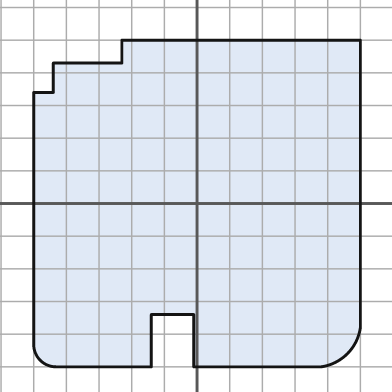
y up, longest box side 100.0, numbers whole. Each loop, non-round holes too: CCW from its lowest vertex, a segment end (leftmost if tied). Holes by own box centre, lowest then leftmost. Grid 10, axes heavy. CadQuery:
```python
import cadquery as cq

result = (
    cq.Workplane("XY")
    .moveTo(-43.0, -50.0)
    .lineTo(-14.0, -50.0)
    .lineTo(-14.0, -34.0)
    .lineTo(-1.0, -34.0)
    .lineTo(-1.0, -50.0)
    .lineTo(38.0, -50.0)
    .threePointArc((46.0, -46.0), (50.0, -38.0))
    .lineTo(50.0, 50.0)
    .lineTo(-23.0, 50.0)
    .lineTo(-23.0, 43.0)
    .lineTo(-44.0, 43.0)
    .lineTo(-44.0, 34.0)
    .lineTo(-50.0, 34.0)
    .lineTo(-50.0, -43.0)
    .threePointArc((-48.0, -48.0), (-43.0, -50.0))
    .close()
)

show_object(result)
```